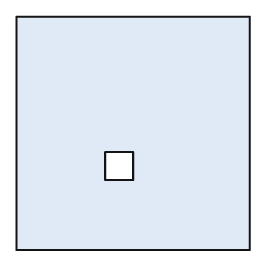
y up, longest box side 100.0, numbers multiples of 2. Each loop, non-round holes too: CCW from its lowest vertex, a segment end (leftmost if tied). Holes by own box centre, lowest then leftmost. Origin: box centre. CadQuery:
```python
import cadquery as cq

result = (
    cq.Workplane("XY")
    .moveTo(-50.0, -50.0)
    .lineTo(50.0, -50.0)
    .lineTo(50.0, 50.0)
    .lineTo(-50.0, 50.0)
    .close()
    .moveTo(-12.0, -20.0)
    .lineTo(0.0, -20.0)
    .lineTo(0.0, -8.0)
    .lineTo(-12.0, -8.0)
    .close()
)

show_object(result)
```